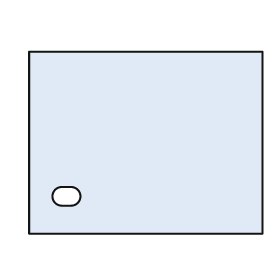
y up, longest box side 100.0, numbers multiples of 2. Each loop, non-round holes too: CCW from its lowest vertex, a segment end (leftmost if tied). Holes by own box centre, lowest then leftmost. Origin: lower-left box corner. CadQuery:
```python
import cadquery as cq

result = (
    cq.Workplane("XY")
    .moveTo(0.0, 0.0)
    .lineTo(100.0, 0.0)
    .lineTo(100.0, 78.0)
    .lineTo(0.0, 78.0)
    .close()
    .moveTo(14.0, 12.0)
    .lineTo(18.0, 12.0)
    .threePointArc((22.0, 16.0), (18.0, 20.0))
    .lineTo(14.0, 20.0)
    .threePointArc((10.0, 16.0), (14.0, 12.0))
    .close()
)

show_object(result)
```